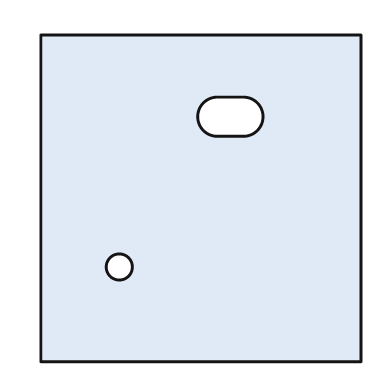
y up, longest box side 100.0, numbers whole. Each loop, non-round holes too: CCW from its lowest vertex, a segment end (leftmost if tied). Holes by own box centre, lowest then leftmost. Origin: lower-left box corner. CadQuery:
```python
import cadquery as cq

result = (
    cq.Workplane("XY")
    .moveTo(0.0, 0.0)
    .lineTo(98.0, 0.0)
    .lineTo(98.0, 100.0)
    .lineTo(0.0, 100.0)
    .close()
    .moveTo(24.0, 29.0)
    .circle(4.0)
    .moveTo(54.0, 69.0)
    .lineTo(62.0, 69.0)
    .threePointArc((68.0, 75.0), (62.0, 81.0))
    .lineTo(54.0, 81.0)
    .threePointArc((48.0, 75.0), (54.0, 69.0))
    .close()
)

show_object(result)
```